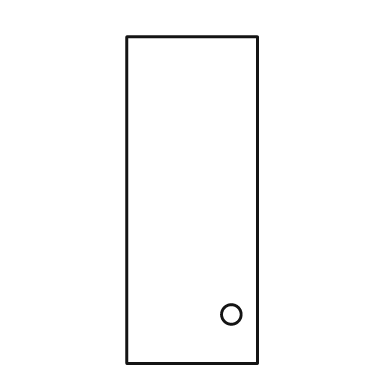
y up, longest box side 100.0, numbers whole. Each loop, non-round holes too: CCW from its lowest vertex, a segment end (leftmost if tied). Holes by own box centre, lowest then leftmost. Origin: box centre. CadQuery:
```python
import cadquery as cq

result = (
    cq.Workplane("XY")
    .moveTo(-20.0, -50.0)
    .lineTo(20.0, -50.0)
    .lineTo(20.0, 50.0)
    .lineTo(-20.0, 50.0)
    .close()
    .moveTo(12.0, -35.0)
    .circle(3.0)
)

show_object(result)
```